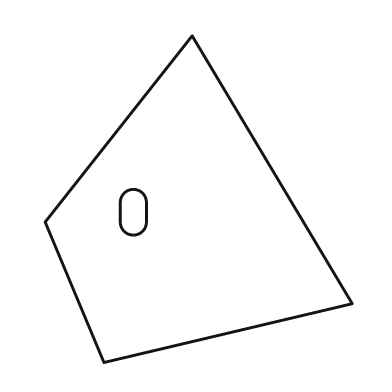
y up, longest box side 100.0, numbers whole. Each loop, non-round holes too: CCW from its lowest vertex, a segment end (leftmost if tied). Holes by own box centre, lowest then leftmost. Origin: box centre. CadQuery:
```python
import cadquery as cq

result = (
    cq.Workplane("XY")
    .moveTo(-29.0, -50.0)
    .lineTo(47.0, -32.0)
    .lineTo(-2.0, 50.0)
    .lineTo(-47.0, -7.0)
    .close()
    .moveTo(-24.0, -7.0)
    .threePointArc((-20.0, -11.0), (-16.0, -7.0))
    .lineTo(-16.0, -1.0)
    .threePointArc((-20.0, 3.0), (-24.0, -1.0))
    .close()
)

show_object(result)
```